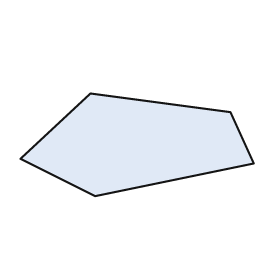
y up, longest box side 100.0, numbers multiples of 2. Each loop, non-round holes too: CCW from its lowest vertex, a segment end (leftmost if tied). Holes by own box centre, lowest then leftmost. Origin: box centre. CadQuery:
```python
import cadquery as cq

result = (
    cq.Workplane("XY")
    .moveTo(-18.0, -22.0)
    .lineTo(50.0, -8.0)
    .lineTo(40.0, 14.0)
    .lineTo(-20.0, 22.0)
    .lineTo(-50.0, -6.0)
    .close()
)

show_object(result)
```